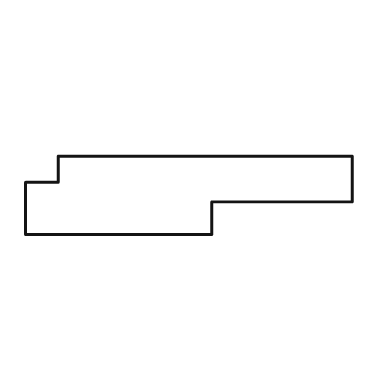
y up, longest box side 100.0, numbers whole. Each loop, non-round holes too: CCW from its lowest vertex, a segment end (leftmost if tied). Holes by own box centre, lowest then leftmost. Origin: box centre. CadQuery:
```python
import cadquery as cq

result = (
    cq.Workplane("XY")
    .moveTo(-50.0, -12.0)
    .lineTo(7.0, -12.0)
    .lineTo(7.0, -2.0)
    .lineTo(50.0, -2.0)
    .lineTo(50.0, 12.0)
    .lineTo(-40.0, 12.0)
    .lineTo(-40.0, 4.0)
    .lineTo(-50.0, 4.0)
    .close()
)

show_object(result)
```